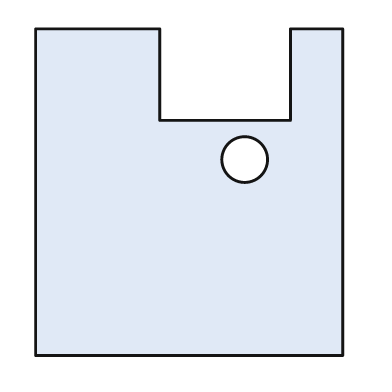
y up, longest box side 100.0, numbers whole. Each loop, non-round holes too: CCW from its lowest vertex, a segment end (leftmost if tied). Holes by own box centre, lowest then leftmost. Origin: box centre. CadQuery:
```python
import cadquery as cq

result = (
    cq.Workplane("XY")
    .moveTo(-47.0, -50.0)
    .lineTo(47.0, -50.0)
    .lineTo(47.0, 50.0)
    .lineTo(31.0, 50.0)
    .lineTo(31.0, 22.0)
    .lineTo(-9.0, 22.0)
    .lineTo(-9.0, 50.0)
    .lineTo(-47.0, 50.0)
    .close()
    .moveTo(17.0, 10.0)
    .circle(7.0)
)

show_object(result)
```